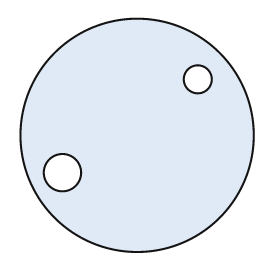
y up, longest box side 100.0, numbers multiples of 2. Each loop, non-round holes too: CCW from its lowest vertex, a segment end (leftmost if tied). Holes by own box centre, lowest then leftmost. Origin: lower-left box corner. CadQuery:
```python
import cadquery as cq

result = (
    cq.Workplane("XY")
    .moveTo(50.0, 50.0)
    .circle(50.0)
    .moveTo(18.0, 34.0)
    .circle(8.0)
    .moveTo(76.0, 74.0)
    .circle(6.0)
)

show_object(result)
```